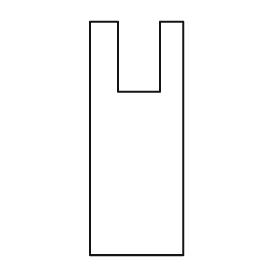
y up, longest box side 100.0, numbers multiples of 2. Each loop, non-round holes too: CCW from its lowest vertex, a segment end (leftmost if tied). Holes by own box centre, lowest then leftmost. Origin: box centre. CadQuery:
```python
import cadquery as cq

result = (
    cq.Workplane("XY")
    .moveTo(-20.0, -50.0)
    .lineTo(20.0, -50.0)
    .lineTo(20.0, 50.0)
    .lineTo(10.0, 50.0)
    .lineTo(10.0, 20.0)
    .lineTo(-8.0, 20.0)
    .lineTo(-8.0, 50.0)
    .lineTo(-20.0, 50.0)
    .close()
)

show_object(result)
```